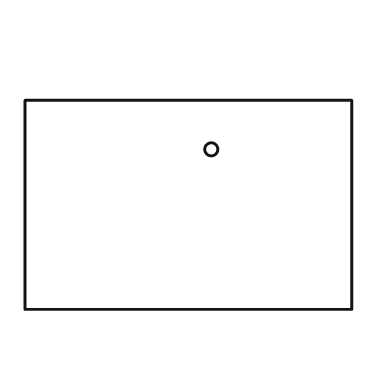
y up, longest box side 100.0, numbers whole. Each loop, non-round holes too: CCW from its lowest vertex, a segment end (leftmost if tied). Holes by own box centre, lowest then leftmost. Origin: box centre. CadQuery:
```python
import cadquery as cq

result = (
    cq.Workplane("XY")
    .moveTo(-50.0, -32.0)
    .lineTo(50.0, -32.0)
    .lineTo(50.0, 32.0)
    .lineTo(-50.0, 32.0)
    .close()
    .moveTo(7.0, 17.0)
    .circle(2.0)
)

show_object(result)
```